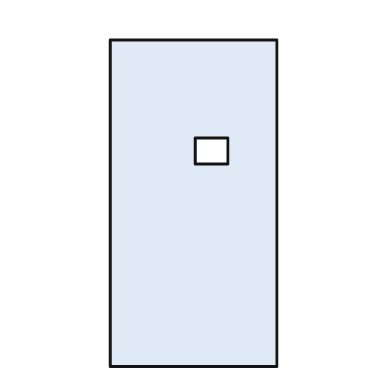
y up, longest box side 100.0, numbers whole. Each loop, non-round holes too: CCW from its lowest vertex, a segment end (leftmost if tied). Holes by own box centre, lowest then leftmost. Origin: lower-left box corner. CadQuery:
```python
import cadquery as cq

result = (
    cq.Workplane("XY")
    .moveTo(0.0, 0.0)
    .lineTo(51.0, 0.0)
    .lineTo(51.0, 100.0)
    .lineTo(0.0, 100.0)
    .close()
    .moveTo(26.0, 62.0)
    .lineTo(36.0, 62.0)
    .lineTo(36.0, 70.0)
    .lineTo(26.0, 70.0)
    .close()
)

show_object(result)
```